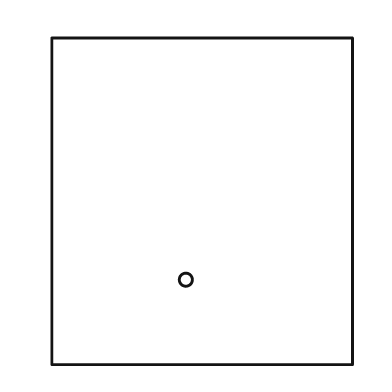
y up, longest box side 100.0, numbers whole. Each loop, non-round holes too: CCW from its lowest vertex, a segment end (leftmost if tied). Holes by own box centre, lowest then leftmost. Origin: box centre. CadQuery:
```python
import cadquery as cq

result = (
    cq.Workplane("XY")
    .moveTo(-46.0, -50.0)
    .lineTo(46.0, -50.0)
    .lineTo(46.0, 50.0)
    .lineTo(-46.0, 50.0)
    .close()
    .moveTo(-5.0, -24.0)
    .circle(2.0)
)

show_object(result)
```